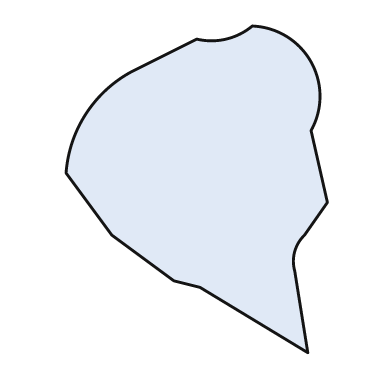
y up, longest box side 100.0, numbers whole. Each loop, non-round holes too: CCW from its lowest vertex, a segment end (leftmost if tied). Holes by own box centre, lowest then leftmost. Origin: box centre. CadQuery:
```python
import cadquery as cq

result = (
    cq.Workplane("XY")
    .moveTo(34.0, -50.0)
    .lineTo(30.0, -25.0)
    .threePointArc((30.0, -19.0), (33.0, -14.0))
    .lineTo(40.0, -4.0)
    .lineTo(35.0, 18.0)
    .threePointArc((35.0, 39.0), (17.0, 50.0))
    .threePointArc((9.0, 46.0), (0.0, 46.0))
    .lineTo(-20.0, 36.0)
    .threePointArc((-34.0, 23.0), (-40.0, 5.0))
    .lineTo(-26.0, -14.0)
    .lineTo(-7.0, -28.0)
    .lineTo(1.0, -30.0)
    .close()
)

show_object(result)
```